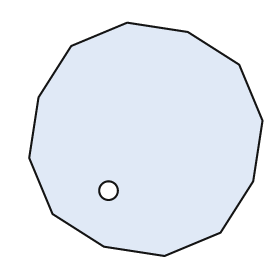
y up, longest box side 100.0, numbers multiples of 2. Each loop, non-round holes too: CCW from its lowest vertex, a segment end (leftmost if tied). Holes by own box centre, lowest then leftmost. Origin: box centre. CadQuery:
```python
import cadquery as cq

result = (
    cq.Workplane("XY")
    .moveTo(8.0, -50.0)
    .lineTo(32.0, -40.0)
    .lineTo(46.0, -18.0)
    .lineTo(50.0, 8.0)
    .lineTo(40.0, 32.0)
    .lineTo(18.0, 46.0)
    .lineTo(-8.0, 50.0)
    .lineTo(-32.0, 40.0)
    .lineTo(-46.0, 18.0)
    .lineTo(-50.0, -8.0)
    .lineTo(-40.0, -32.0)
    .lineTo(-18.0, -46.0)
    .close()
    .moveTo(-16.0, -22.0)
    .circle(4.0)
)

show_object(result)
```